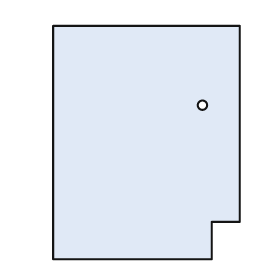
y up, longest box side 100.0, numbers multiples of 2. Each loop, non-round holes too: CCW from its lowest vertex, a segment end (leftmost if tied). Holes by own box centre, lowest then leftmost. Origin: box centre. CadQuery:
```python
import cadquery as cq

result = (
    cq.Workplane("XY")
    .moveTo(-40.0, -50.0)
    .lineTo(28.0, -50.0)
    .lineTo(28.0, -34.0)
    .lineTo(40.0, -34.0)
    .lineTo(40.0, 50.0)
    .lineTo(-40.0, 50.0)
    .close()
    .moveTo(24.0, 16.0)
    .circle(2.0)
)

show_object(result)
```